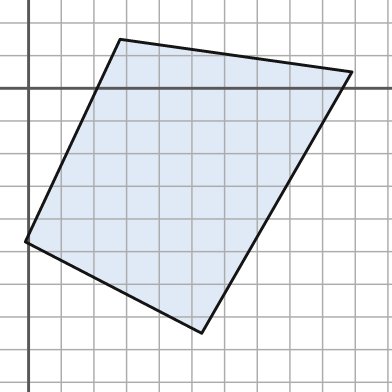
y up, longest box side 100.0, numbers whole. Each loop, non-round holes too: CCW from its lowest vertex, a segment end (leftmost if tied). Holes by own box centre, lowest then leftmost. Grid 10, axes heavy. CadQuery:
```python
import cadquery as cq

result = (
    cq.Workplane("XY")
    .moveTo(53.0, -75.0)
    .lineTo(99.0, 5.0)
    .lineTo(28.0, 15.0)
    .lineTo(-1.0, -47.0)
    .close()
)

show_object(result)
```